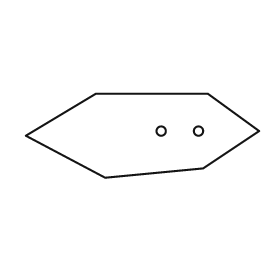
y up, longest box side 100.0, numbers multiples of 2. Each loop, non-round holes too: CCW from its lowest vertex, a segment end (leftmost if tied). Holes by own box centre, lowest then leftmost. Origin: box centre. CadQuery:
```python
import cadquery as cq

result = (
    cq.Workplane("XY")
    .moveTo(-16.0, -18.0)
    .lineTo(26.0, -14.0)
    .lineTo(50.0, 2.0)
    .lineTo(28.0, 18.0)
    .lineTo(-20.0, 18.0)
    .lineTo(-50.0, 0.0)
    .close()
    .moveTo(8.0, 2.0)
    .circle(2.0)
    .moveTo(24.0, 2.0)
    .circle(2.0)
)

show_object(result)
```